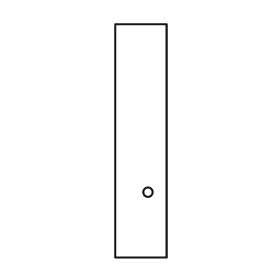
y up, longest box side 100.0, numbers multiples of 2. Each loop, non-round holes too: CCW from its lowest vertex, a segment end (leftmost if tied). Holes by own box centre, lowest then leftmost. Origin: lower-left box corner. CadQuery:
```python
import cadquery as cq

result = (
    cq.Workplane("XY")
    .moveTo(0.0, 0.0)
    .lineTo(22.0, 0.0)
    .lineTo(22.0, 100.0)
    .lineTo(0.0, 100.0)
    .close()
    .moveTo(14.0, 28.0)
    .circle(2.0)
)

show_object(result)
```